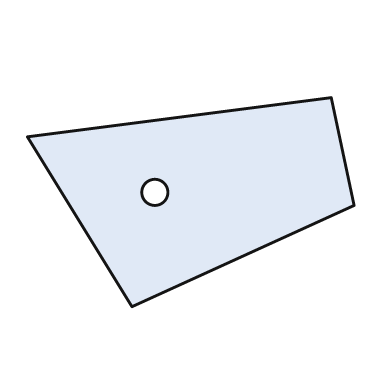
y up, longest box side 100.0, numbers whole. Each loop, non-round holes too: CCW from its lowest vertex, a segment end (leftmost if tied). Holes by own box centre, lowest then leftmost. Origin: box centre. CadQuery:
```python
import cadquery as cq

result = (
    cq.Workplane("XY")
    .moveTo(-18.0, -32.0)
    .lineTo(50.0, -1.0)
    .lineTo(43.0, 32.0)
    .lineTo(-50.0, 20.0)
    .close()
    .moveTo(-11.0, 3.0)
    .circle(4.0)
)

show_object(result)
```